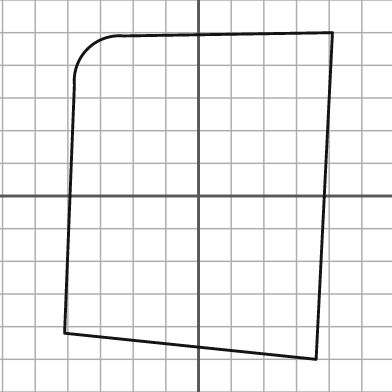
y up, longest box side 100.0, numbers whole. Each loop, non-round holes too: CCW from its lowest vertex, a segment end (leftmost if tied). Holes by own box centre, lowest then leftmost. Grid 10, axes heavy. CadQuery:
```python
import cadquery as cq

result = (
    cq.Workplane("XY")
    .moveTo(36.0, -50.0)
    .lineTo(41.0, 50.0)
    .lineTo(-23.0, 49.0)
    .threePointArc((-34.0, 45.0), (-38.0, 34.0))
    .lineTo(-41.0, -42.0)
    .close()
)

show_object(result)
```